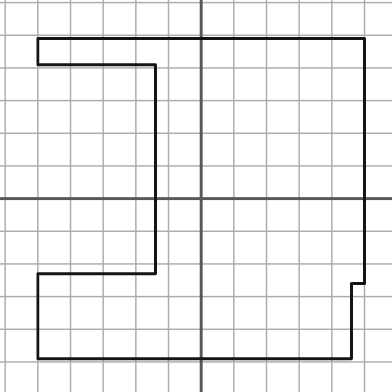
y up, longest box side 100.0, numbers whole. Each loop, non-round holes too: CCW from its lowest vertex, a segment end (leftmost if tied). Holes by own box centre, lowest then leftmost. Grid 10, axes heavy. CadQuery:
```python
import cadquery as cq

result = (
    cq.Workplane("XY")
    .moveTo(-50.0, -49.0)
    .lineTo(46.0, -49.0)
    .lineTo(46.0, -26.0)
    .lineTo(50.0, -26.0)
    .lineTo(50.0, 49.0)
    .lineTo(-50.0, 49.0)
    .lineTo(-50.0, 41.0)
    .lineTo(-14.0, 41.0)
    .lineTo(-14.0, -23.0)
    .lineTo(-50.0, -23.0)
    .close()
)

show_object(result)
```